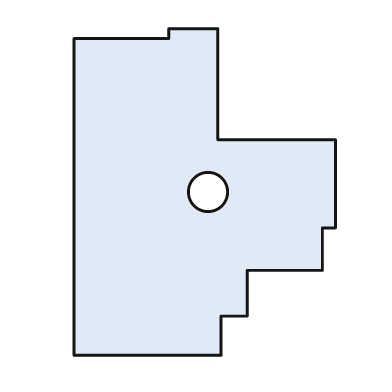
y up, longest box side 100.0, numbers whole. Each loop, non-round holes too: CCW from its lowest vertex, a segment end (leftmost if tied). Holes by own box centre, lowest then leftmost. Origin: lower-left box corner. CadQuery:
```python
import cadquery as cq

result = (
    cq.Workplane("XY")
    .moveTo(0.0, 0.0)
    .lineTo(45.0, 0.0)
    .lineTo(45.0, 12.0)
    .lineTo(53.0, 12.0)
    .lineTo(53.0, 26.0)
    .lineTo(76.0, 26.0)
    .lineTo(76.0, 39.0)
    .lineTo(80.0, 39.0)
    .lineTo(80.0, 66.0)
    .lineTo(44.0, 66.0)
    .lineTo(44.0, 100.0)
    .lineTo(29.0, 100.0)
    .lineTo(29.0, 97.0)
    .lineTo(0.0, 97.0)
    .close()
    .moveTo(41.0, 50.0)
    .circle(6.0)
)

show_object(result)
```